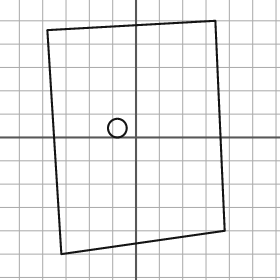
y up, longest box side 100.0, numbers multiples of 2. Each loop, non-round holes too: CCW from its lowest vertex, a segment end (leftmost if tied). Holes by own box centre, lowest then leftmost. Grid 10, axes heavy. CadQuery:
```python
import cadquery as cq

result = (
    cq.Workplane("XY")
    .moveTo(-32.0, -50.0)
    .lineTo(38.0, -40.0)
    .lineTo(34.0, 50.0)
    .lineTo(-38.0, 46.0)
    .close()
    .moveTo(-8.0, 4.0)
    .circle(4.0)
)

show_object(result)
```